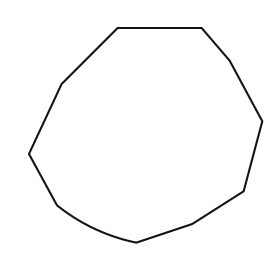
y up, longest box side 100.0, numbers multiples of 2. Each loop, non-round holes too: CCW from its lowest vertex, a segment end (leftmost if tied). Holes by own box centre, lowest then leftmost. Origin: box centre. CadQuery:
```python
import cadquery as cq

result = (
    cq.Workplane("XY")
    .moveTo(-4.0, -46.0)
    .lineTo(20.0, -38.0)
    .lineTo(42.0, -24.0)
    .lineTo(50.0, 6.0)
    .lineTo(36.0, 32.0)
    .lineTo(24.0, 46.0)
    .lineTo(-12.0, 46.0)
    .lineTo(-36.0, 22.0)
    .lineTo(-50.0, -8.0)
    .lineTo(-38.0, -30.0)
    .threePointArc((-22.0, -40.0), (-4.0, -46.0))
    .close()
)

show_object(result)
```